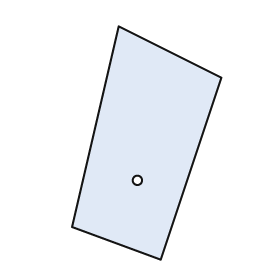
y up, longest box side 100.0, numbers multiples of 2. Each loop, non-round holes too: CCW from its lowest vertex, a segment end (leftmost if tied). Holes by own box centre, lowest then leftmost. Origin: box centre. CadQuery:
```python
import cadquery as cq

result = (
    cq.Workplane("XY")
    .moveTo(6.0, -50.0)
    .lineTo(32.0, 28.0)
    .lineTo(-12.0, 50.0)
    .lineTo(-32.0, -36.0)
    .close()
    .moveTo(-4.0, -16.0)
    .circle(2.0)
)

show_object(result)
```